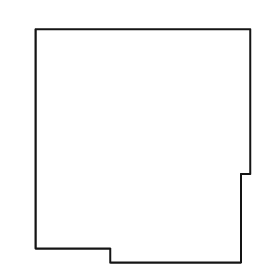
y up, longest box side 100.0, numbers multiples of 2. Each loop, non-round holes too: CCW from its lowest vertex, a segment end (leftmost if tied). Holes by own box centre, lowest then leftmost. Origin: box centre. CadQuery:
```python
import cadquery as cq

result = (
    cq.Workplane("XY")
    .moveTo(-14.0, -50.0)
    .lineTo(42.0, -50.0)
    .lineTo(42.0, -12.0)
    .lineTo(46.0, -12.0)
    .lineTo(46.0, 50.0)
    .lineTo(-46.0, 50.0)
    .lineTo(-46.0, -44.0)
    .lineTo(-14.0, -44.0)
    .close()
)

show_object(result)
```